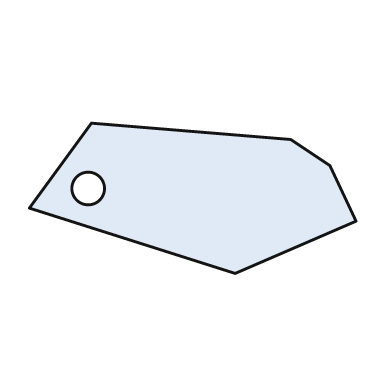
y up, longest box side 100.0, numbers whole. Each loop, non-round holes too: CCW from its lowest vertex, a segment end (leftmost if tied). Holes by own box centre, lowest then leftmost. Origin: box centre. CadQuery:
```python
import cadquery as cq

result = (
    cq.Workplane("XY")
    .moveTo(13.0, -23.0)
    .lineTo(50.0, -7.0)
    .lineTo(42.0, 10.0)
    .lineTo(30.0, 18.0)
    .lineTo(-31.0, 23.0)
    .lineTo(-50.0, -3.0)
    .close()
    .moveTo(-32.0, 3.0)
    .circle(5.0)
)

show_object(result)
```